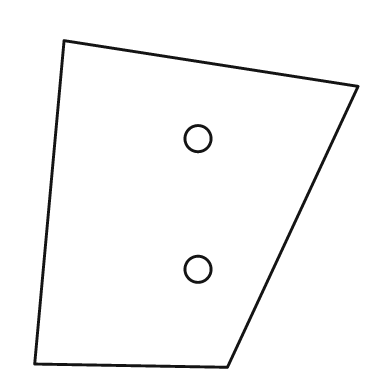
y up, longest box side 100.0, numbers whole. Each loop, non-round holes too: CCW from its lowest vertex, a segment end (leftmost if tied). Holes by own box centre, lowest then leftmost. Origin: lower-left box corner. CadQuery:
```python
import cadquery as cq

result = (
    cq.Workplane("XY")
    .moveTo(59.0, 0.0)
    .lineTo(99.0, 86.0)
    .lineTo(9.0, 100.0)
    .lineTo(0.0, 1.0)
    .close()
    .moveTo(50.0, 30.0)
    .circle(4.0)
    .moveTo(50.0, 70.0)
    .circle(4.0)
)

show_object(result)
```